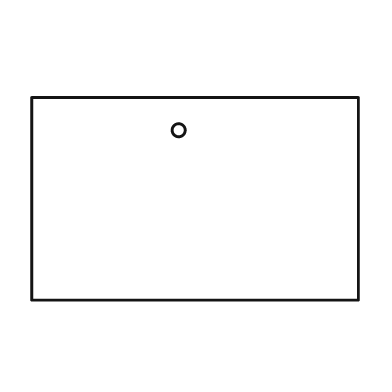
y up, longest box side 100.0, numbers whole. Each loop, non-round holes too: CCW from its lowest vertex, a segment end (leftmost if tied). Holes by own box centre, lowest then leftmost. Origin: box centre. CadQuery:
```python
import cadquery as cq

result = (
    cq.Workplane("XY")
    .moveTo(-50.0, -31.0)
    .lineTo(50.0, -31.0)
    .lineTo(50.0, 31.0)
    .lineTo(-50.0, 31.0)
    .close()
    .moveTo(-5.0, 21.0)
    .circle(2.0)
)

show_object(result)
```